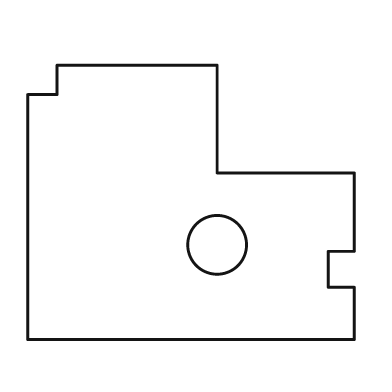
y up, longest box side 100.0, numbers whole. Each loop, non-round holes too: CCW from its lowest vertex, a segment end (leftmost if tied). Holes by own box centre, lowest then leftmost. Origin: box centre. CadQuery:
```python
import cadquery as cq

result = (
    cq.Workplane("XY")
    .moveTo(-50.0, -42.0)
    .lineTo(50.0, -42.0)
    .lineTo(50.0, -26.0)
    .lineTo(42.0, -26.0)
    .lineTo(42.0, -15.0)
    .lineTo(50.0, -15.0)
    .lineTo(50.0, 9.0)
    .lineTo(8.0, 9.0)
    .lineTo(8.0, 42.0)
    .lineTo(-41.0, 42.0)
    .lineTo(-41.0, 33.0)
    .lineTo(-50.0, 33.0)
    .close()
    .moveTo(8.0, -13.0)
    .circle(9.0)
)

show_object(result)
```